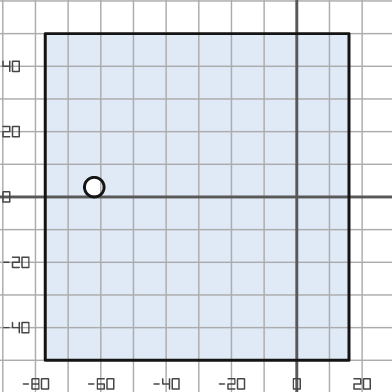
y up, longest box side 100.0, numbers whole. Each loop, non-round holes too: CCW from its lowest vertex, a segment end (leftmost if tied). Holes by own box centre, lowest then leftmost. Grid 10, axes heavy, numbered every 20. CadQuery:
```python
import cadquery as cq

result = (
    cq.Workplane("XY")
    .moveTo(-77.0, -50.0)
    .lineTo(16.0, -50.0)
    .lineTo(16.0, 50.0)
    .lineTo(-77.0, 50.0)
    .close()
    .moveTo(-62.0, 3.0)
    .circle(3.0)
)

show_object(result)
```